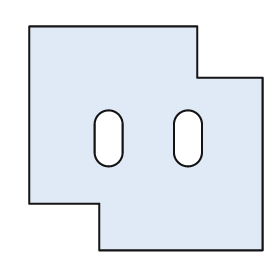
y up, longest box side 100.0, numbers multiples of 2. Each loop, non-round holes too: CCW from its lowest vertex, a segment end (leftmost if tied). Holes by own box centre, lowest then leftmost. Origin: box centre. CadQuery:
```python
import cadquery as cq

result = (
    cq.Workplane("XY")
    .moveTo(-20.0, -48.0)
    .lineTo(50.0, -48.0)
    .lineTo(50.0, 26.0)
    .lineTo(22.0, 26.0)
    .lineTo(22.0, 48.0)
    .lineTo(-50.0, 48.0)
    .lineTo(-50.0, -28.0)
    .lineTo(-20.0, -28.0)
    .close()
    .moveTo(-22.0, -6.0)
    .threePointArc((-16.0, -12.0), (-10.0, -6.0))
    .lineTo(-10.0, 6.0)
    .threePointArc((-16.0, 12.0), (-22.0, 6.0))
    .close()
    .moveTo(12.0, -6.0)
    .threePointArc((18.0, -12.0), (24.0, -6.0))
    .lineTo(24.0, 6.0)
    .threePointArc((18.0, 12.0), (12.0, 6.0))
    .close()
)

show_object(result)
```